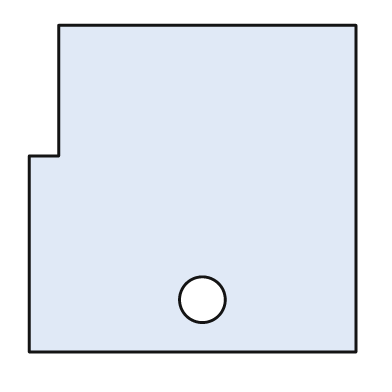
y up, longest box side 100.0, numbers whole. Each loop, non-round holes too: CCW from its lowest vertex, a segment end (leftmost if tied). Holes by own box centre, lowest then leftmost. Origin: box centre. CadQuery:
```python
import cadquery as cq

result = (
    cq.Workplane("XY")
    .moveTo(-50.0, -50.0)
    .lineTo(50.0, -50.0)
    .lineTo(50.0, 50.0)
    .lineTo(-41.0, 50.0)
    .lineTo(-41.0, 10.0)
    .lineTo(-50.0, 10.0)
    .close()
    .moveTo(3.0, -34.0)
    .circle(7.0)
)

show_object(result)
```